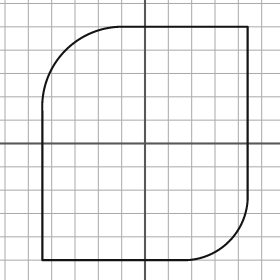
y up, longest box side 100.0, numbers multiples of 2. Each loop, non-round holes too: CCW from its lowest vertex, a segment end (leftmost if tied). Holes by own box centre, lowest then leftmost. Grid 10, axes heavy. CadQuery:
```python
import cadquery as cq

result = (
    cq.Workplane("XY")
    .moveTo(-44.0, -50.0)
    .lineTo(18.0, -50.0)
    .threePointArc((36.0, -42.0), (44.0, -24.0))
    .lineTo(44.0, 50.0)
    .lineTo(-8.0, 50.0)
    .threePointArc((-34.0, 40.0), (-44.0, 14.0))
    .close()
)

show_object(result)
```